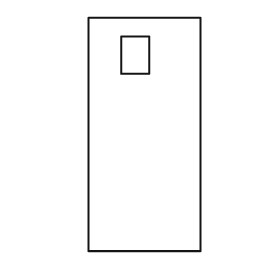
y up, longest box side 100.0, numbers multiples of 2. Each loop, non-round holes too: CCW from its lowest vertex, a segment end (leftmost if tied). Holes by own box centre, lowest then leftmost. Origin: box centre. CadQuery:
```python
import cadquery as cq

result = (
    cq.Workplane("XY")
    .moveTo(-24.0, -50.0)
    .lineTo(24.0, -50.0)
    .lineTo(24.0, 50.0)
    .lineTo(-24.0, 50.0)
    .close()
    .moveTo(-10.0, 26.0)
    .lineTo(2.0, 26.0)
    .lineTo(2.0, 42.0)
    .lineTo(-10.0, 42.0)
    .close()
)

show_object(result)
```